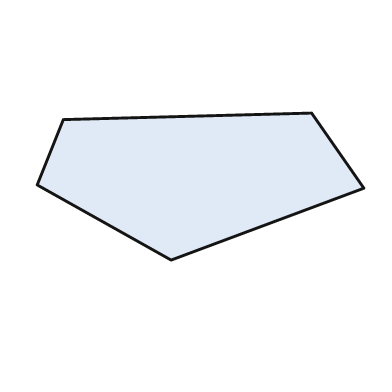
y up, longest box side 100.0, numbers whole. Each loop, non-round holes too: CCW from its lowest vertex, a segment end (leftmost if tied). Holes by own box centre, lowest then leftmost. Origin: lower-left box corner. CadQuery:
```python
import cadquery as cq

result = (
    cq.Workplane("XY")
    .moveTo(41.0, 0.0)
    .lineTo(100.0, 22.0)
    .lineTo(84.0, 45.0)
    .lineTo(8.0, 43.0)
    .lineTo(0.0, 23.0)
    .close()
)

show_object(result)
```